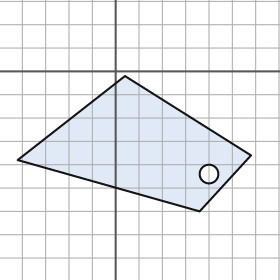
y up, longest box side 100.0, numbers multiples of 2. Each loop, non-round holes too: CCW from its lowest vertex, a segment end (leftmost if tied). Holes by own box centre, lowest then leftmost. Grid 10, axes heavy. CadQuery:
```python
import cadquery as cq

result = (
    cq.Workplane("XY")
    .moveTo(36.0, -60.0)
    .lineTo(58.0, -36.0)
    .lineTo(4.0, -2.0)
    .lineTo(-42.0, -38.0)
    .close()
    .moveTo(40.0, -44.0)
    .circle(4.0)
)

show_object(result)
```